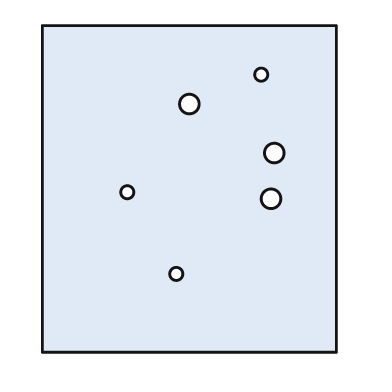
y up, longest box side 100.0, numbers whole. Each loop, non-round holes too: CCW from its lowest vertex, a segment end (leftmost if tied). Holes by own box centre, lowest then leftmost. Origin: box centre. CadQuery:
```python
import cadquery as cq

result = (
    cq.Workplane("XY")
    .moveTo(-45.0, -50.0)
    .lineTo(45.0, -50.0)
    .lineTo(45.0, 50.0)
    .lineTo(-45.0, 50.0)
    .close()
    .moveTo(-4.0, -26.0)
    .circle(2.0)
    .moveTo(25.0, -3.0)
    .circle(3.0)
    .moveTo(-19.0, -1.0)
    .circle(2.0)
    .moveTo(26.0, 11.0)
    .circle(3.0)
    .moveTo(0.0, 26.0)
    .circle(3.0)
    .moveTo(22.0, 35.0)
    .circle(2.0)
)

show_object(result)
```